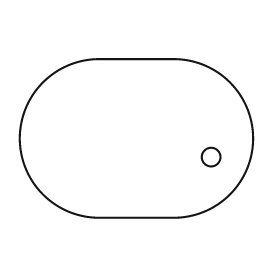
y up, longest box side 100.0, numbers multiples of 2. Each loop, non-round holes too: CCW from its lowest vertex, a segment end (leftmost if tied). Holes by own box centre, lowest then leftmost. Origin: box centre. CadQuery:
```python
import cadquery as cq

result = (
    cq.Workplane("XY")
    .moveTo(-16.0, -34.0)
    .lineTo(16.0, -34.0)
    .threePointArc((50.0, 0.0), (16.0, 34.0))
    .lineTo(-16.0, 34.0)
    .threePointArc((-50.0, 0.0), (-16.0, -34.0))
    .close()
    .moveTo(32.0, -8.0)
    .circle(4.0)
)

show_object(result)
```